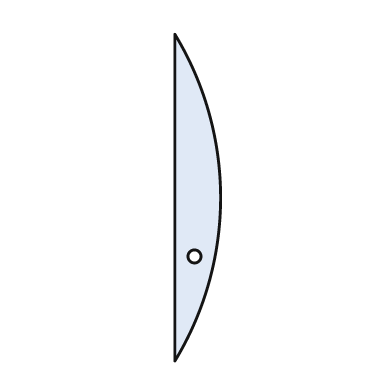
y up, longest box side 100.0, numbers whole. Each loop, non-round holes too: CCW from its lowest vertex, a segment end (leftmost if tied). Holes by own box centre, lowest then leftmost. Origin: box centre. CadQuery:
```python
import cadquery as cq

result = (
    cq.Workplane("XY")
    .moveTo(-7.0, -50.0)
    .threePointArc((7.0, 0.0), (-7.0, 50.0))
    .close()
    .moveTo(-1.0, -18.0)
    .circle(2.0)
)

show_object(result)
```